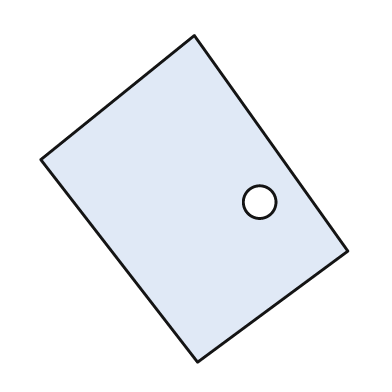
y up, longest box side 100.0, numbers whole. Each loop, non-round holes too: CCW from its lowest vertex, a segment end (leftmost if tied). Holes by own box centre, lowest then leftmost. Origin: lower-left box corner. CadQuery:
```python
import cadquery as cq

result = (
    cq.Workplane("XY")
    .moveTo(48.0, 0.0)
    .lineTo(94.0, 34.0)
    .lineTo(47.0, 100.0)
    .lineTo(0.0, 62.0)
    .close()
    .moveTo(67.0, 49.0)
    .circle(5.0)
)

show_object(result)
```